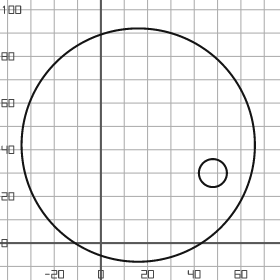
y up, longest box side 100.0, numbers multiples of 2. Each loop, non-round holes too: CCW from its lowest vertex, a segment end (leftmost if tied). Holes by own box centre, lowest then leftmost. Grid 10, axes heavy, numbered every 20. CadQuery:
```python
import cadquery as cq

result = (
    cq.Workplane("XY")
    .moveTo(16.0, 42.0)
    .circle(50.0)
    .moveTo(48.0, 30.0)
    .circle(6.0)
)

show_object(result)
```